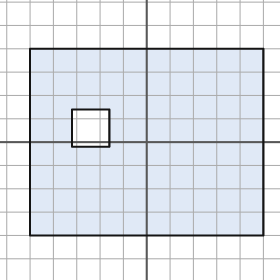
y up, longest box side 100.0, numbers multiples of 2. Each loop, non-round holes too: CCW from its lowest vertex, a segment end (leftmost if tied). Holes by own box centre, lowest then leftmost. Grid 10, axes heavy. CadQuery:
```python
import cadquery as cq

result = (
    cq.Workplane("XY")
    .moveTo(-50.0, -40.0)
    .lineTo(50.0, -40.0)
    .lineTo(50.0, 40.0)
    .lineTo(-50.0, 40.0)
    .close()
    .moveTo(-32.0, -2.0)
    .lineTo(-16.0, -2.0)
    .lineTo(-16.0, 14.0)
    .lineTo(-32.0, 14.0)
    .close()
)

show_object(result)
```